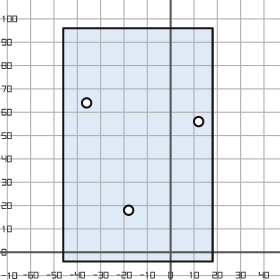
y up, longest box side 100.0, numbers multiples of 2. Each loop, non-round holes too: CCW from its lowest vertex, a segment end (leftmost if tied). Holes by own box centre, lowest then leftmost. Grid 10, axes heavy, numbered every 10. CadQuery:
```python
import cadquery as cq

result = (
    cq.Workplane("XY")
    .moveTo(-46.0, -4.0)
    .lineTo(18.0, -4.0)
    .lineTo(18.0, 96.0)
    .lineTo(-46.0, 96.0)
    .close()
    .moveTo(-18.0, 18.0)
    .circle(2.0)
    .moveTo(12.0, 56.0)
    .circle(2.0)
    .moveTo(-36.0, 64.0)
    .circle(2.0)
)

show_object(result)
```